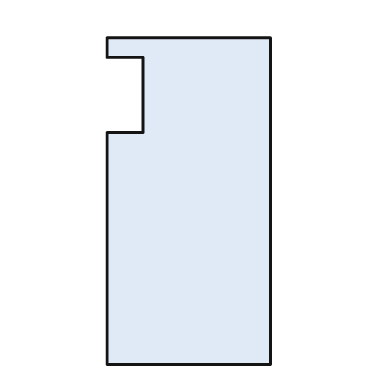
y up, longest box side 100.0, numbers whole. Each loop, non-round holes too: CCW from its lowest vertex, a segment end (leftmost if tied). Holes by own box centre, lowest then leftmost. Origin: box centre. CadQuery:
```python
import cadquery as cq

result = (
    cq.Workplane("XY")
    .moveTo(-25.0, -50.0)
    .lineTo(25.0, -50.0)
    .lineTo(25.0, 50.0)
    .lineTo(-25.0, 50.0)
    .lineTo(-25.0, 44.0)
    .lineTo(-14.0, 44.0)
    .lineTo(-14.0, 21.0)
    .lineTo(-25.0, 21.0)
    .close()
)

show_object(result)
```